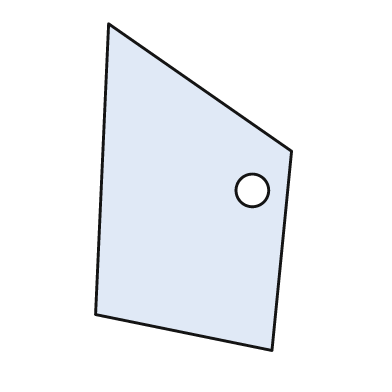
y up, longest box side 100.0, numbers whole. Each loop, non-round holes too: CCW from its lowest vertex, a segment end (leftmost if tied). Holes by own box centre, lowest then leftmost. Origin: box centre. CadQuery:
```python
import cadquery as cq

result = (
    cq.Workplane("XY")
    .moveTo(24.0, -50.0)
    .lineTo(30.0, 11.0)
    .lineTo(-26.0, 50.0)
    .lineTo(-30.0, -39.0)
    .close()
    .moveTo(18.0, -1.0)
    .circle(5.0)
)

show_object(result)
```